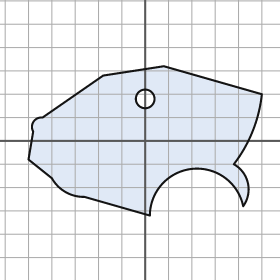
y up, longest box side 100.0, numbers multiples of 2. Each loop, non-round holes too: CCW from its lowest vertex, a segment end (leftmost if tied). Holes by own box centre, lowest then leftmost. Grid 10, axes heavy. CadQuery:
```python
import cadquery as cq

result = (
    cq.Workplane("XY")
    .moveTo(2.0, -32.0)
    .threePointArc((20.0, -12.0), (42.0, -28.0))
    .threePointArc((44.0, -18.0), (38.0, -10.0))
    .threePointArc((46.0, 4.0), (50.0, 20.0))
    .lineTo(8.0, 32.0)
    .lineTo(-18.0, 28.0)
    .lineTo(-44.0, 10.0)
    .threePointArc((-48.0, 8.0), (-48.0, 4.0))
    .lineTo(-50.0, -8.0)
    .lineTo(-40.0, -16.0)
    .threePointArc((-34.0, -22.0), (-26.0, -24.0))
    .close()
    .moveTo(0.0, 18.0)
    .circle(4.0)
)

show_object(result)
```